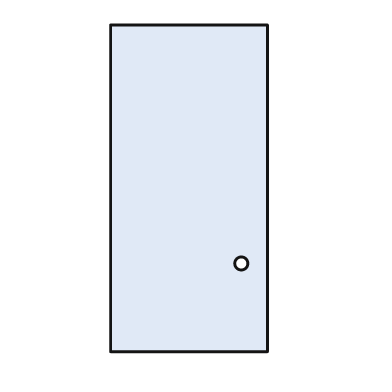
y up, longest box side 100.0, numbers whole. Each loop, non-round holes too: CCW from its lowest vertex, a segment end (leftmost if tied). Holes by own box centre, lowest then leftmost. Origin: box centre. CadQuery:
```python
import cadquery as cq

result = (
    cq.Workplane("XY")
    .moveTo(-24.0, -50.0)
    .lineTo(24.0, -50.0)
    .lineTo(24.0, 50.0)
    .lineTo(-24.0, 50.0)
    .close()
    .moveTo(16.0, -23.0)
    .circle(2.0)
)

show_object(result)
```